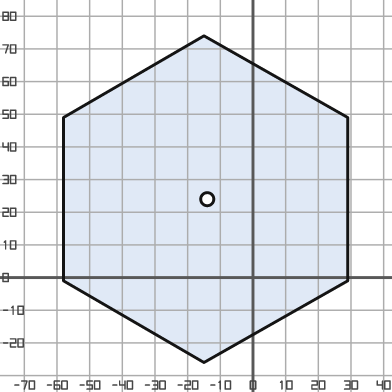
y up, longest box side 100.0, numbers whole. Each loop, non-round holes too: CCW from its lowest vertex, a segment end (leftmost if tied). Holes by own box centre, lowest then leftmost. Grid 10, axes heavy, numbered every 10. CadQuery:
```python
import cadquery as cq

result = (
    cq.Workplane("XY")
    .moveTo(-15.0, -26.0)
    .lineTo(29.0, -1.0)
    .lineTo(29.0, 49.0)
    .lineTo(-15.0, 74.0)
    .lineTo(-58.0, 49.0)
    .lineTo(-58.0, -1.0)
    .close()
    .moveTo(-14.0, 24.0)
    .circle(2.0)
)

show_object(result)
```